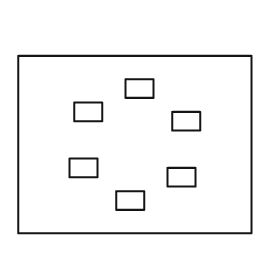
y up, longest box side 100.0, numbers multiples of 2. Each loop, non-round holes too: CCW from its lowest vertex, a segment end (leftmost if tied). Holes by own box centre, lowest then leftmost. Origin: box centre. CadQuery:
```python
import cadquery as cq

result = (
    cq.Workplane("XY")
    .moveTo(-50.0, -38.0)
    .lineTo(50.0, -38.0)
    .lineTo(50.0, 38.0)
    .lineTo(-50.0, 38.0)
    .close()
    .moveTo(-8.0, -28.0)
    .lineTo(4.0, -28.0)
    .lineTo(4.0, -20.0)
    .lineTo(-8.0, -20.0)
    .close()
    .moveTo(14.0, -18.0)
    .lineTo(26.0, -18.0)
    .lineTo(26.0, -10.0)
    .lineTo(14.0, -10.0)
    .close()
    .moveTo(-28.0, -14.0)
    .lineTo(-16.0, -14.0)
    .lineTo(-16.0, -6.0)
    .lineTo(-28.0, -6.0)
    .close()
    .moveTo(16.0, 6.0)
    .lineTo(28.0, 6.0)
    .lineTo(28.0, 14.0)
    .lineTo(16.0, 14.0)
    .close()
    .moveTo(-26.0, 10.0)
    .lineTo(-14.0, 10.0)
    .lineTo(-14.0, 18.0)
    .lineTo(-26.0, 18.0)
    .close()
    .moveTo(-4.0, 20.0)
    .lineTo(8.0, 20.0)
    .lineTo(8.0, 28.0)
    .lineTo(-4.0, 28.0)
    .close()
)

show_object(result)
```